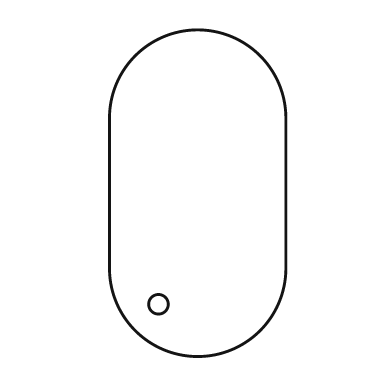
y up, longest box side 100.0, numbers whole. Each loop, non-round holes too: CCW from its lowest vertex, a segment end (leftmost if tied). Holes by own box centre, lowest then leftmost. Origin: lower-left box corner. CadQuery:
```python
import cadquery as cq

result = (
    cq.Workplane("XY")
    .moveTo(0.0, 27.0)
    .threePointArc((27.0, 0.0), (54.0, 27.0))
    .lineTo(54.0, 73.0)
    .threePointArc((27.0, 100.0), (0.0, 73.0))
    .close()
    .moveTo(15.0, 16.0)
    .circle(3.0)
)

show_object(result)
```